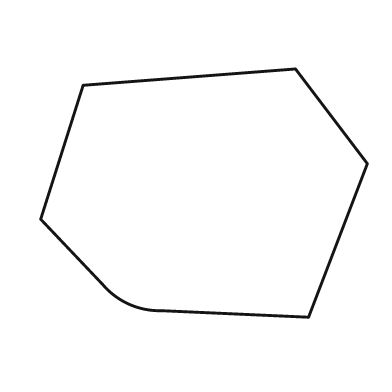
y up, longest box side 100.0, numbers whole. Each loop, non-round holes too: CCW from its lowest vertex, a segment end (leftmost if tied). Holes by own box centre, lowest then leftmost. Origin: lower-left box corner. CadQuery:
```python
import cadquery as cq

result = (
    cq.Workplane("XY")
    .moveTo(82.0, 0.0)
    .lineTo(100.0, 47.0)
    .lineTo(78.0, 76.0)
    .lineTo(13.0, 71.0)
    .lineTo(0.0, 30.0)
    .lineTo(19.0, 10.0)
    .threePointArc((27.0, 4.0), (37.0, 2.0))
    .close()
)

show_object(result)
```